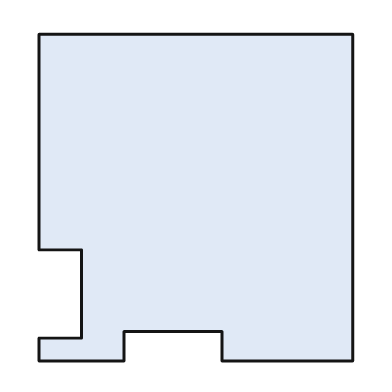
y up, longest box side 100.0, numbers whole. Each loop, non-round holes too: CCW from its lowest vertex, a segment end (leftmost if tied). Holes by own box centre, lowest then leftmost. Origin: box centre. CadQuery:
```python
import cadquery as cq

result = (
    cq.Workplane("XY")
    .moveTo(-48.0, -50.0)
    .lineTo(-22.0, -50.0)
    .lineTo(-22.0, -41.0)
    .lineTo(8.0, -41.0)
    .lineTo(8.0, -50.0)
    .lineTo(48.0, -50.0)
    .lineTo(48.0, 50.0)
    .lineTo(-48.0, 50.0)
    .lineTo(-48.0, -16.0)
    .lineTo(-35.0, -16.0)
    .lineTo(-35.0, -43.0)
    .lineTo(-48.0, -43.0)
    .close()
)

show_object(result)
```